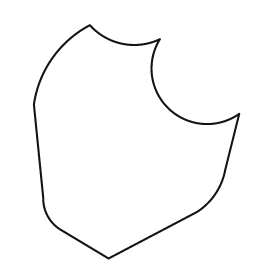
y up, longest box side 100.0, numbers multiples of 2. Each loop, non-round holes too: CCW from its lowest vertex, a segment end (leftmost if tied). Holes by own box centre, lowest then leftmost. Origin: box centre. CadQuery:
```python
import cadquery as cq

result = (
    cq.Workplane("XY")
    .moveTo(-12.0, -50.0)
    .lineTo(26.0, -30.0)
    .threePointArc((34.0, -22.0), (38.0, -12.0))
    .lineTo(44.0, 12.0)
    .threePointArc((14.0, 14.0), (10.0, 44.0))
    .threePointArc((-6.0, 42.0), (-20.0, 50.0))
    .threePointArc((-36.0, 36.0), (-44.0, 16.0))
    .lineTo(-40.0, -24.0)
    .threePointArc((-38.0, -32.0), (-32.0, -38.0))
    .close()
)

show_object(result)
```